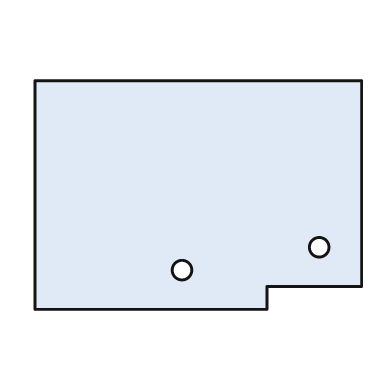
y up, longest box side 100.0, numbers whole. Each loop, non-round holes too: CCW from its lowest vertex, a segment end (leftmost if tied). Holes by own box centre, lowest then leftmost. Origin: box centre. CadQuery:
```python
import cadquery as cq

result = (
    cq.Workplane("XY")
    .moveTo(-50.0, -35.0)
    .lineTo(21.0, -35.0)
    .lineTo(21.0, -28.0)
    .lineTo(50.0, -28.0)
    .lineTo(50.0, 35.0)
    .lineTo(-50.0, 35.0)
    .close()
    .moveTo(-5.0, -23.0)
    .circle(3.0)
    .moveTo(37.0, -16.0)
    .circle(3.0)
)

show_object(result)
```